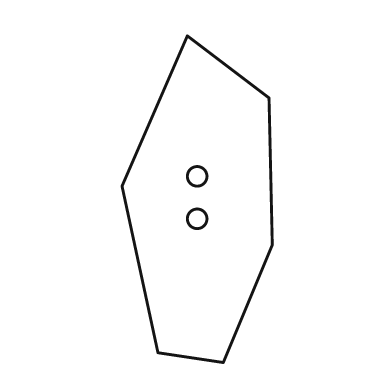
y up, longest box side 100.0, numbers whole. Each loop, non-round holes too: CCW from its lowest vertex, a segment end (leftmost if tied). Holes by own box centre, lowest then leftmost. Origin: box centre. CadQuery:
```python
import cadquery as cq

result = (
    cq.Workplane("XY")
    .moveTo(8.0, -50.0)
    .lineTo(23.0, -14.0)
    .lineTo(22.0, 31.0)
    .lineTo(-3.0, 50.0)
    .lineTo(-23.0, 4.0)
    .lineTo(-12.0, -47.0)
    .close()
    .moveTo(0.0, -6.0)
    .circle(3.0)
    .moveTo(0.0, 7.0)
    .circle(3.0)
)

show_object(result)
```